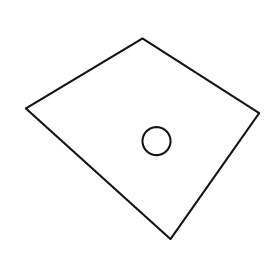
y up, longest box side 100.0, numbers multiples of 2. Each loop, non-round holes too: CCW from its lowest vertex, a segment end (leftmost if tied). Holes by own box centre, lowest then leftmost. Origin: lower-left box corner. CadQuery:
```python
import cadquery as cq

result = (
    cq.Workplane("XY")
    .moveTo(62.0, 0.0)
    .lineTo(100.0, 54.0)
    .lineTo(50.0, 86.0)
    .lineTo(0.0, 56.0)
    .close()
    .moveTo(56.0, 42.0)
    .circle(6.0)
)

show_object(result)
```